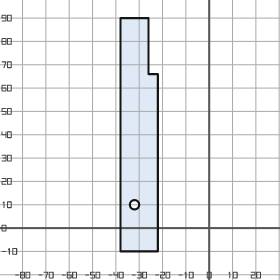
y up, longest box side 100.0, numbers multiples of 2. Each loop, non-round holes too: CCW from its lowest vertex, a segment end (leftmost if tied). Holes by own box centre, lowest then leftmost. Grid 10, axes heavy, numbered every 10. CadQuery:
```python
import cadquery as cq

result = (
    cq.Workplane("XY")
    .moveTo(-38.0, -10.0)
    .lineTo(-22.0, -10.0)
    .lineTo(-22.0, 66.0)
    .lineTo(-26.0, 66.0)
    .lineTo(-26.0, 90.0)
    .lineTo(-38.0, 90.0)
    .close()
    .moveTo(-32.0, 10.0)
    .circle(2.0)
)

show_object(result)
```